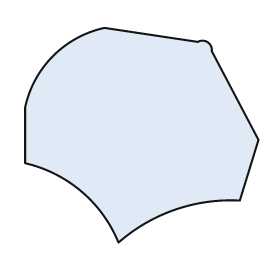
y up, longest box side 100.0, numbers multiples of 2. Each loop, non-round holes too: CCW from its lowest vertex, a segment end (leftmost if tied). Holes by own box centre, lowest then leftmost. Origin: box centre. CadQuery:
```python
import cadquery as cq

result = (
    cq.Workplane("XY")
    .moveTo(-10.0, -46.0)
    .threePointArc((14.0, -32.0), (42.0, -28.0))
    .lineTo(50.0, -2.0)
    .lineTo(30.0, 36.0)
    .threePointArc((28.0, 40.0), (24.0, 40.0))
    .lineTo(-16.0, 46.0)
    .threePointArc((-38.0, 34.0), (-50.0, 12.0))
    .lineTo(-50.0, -12.0)
    .threePointArc((-26.0, -24.0), (-10.0, -46.0))
    .close()
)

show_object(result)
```